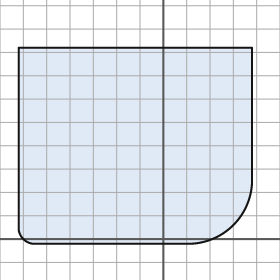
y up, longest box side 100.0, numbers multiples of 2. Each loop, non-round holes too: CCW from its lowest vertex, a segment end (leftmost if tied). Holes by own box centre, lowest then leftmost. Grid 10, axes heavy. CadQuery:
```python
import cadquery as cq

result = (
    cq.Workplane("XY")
    .moveTo(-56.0, -2.0)
    .lineTo(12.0, -2.0)
    .threePointArc((30.0, 6.0), (38.0, 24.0))
    .lineTo(38.0, 82.0)
    .lineTo(-62.0, 82.0)
    .lineTo(-62.0, 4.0)
    .threePointArc((-60.0, 0.0), (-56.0, -2.0))
    .close()
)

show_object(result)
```